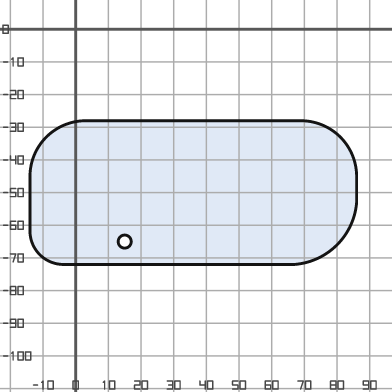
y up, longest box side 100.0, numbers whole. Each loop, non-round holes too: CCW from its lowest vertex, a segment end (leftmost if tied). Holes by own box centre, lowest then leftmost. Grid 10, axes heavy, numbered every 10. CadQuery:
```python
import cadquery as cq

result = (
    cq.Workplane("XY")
    .moveTo(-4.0, -72.0)
    .lineTo(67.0, -72.0)
    .threePointArc((80.0, -66.0), (86.0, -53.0))
    .lineTo(86.0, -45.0)
    .threePointArc((81.0, -33.0), (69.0, -28.0))
    .lineTo(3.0, -28.0)
    .threePointArc((-9.0, -33.0), (-14.0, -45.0))
    .lineTo(-14.0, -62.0)
    .threePointArc((-11.0, -69.0), (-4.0, -72.0))
    .close()
    .moveTo(15.0, -65.0)
    .circle(2.0)
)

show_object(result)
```